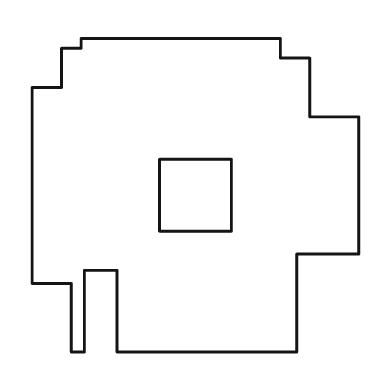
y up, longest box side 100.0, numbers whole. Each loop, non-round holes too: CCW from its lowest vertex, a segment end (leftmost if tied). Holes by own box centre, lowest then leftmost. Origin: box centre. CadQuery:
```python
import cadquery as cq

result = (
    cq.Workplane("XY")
    .moveTo(-38.0, -48.0)
    .lineTo(-34.0, -48.0)
    .lineTo(-34.0, -23.0)
    .lineTo(-24.0, -23.0)
    .lineTo(-24.0, -48.0)
    .lineTo(31.0, -48.0)
    .lineTo(31.0, -18.0)
    .lineTo(50.0, -18.0)
    .lineTo(50.0, 24.0)
    .lineTo(35.0, 24.0)
    .lineTo(35.0, 42.0)
    .lineTo(26.0, 42.0)
    .lineTo(26.0, 48.0)
    .lineTo(-35.0, 48.0)
    .lineTo(-35.0, 45.0)
    .lineTo(-41.0, 45.0)
    .lineTo(-41.0, 33.0)
    .lineTo(-50.0, 33.0)
    .lineTo(-50.0, -27.0)
    .lineTo(-38.0, -27.0)
    .close()
    .moveTo(-11.0, -11.0)
    .lineTo(11.0, -11.0)
    .lineTo(11.0, 11.0)
    .lineTo(-11.0, 11.0)
    .close()
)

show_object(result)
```